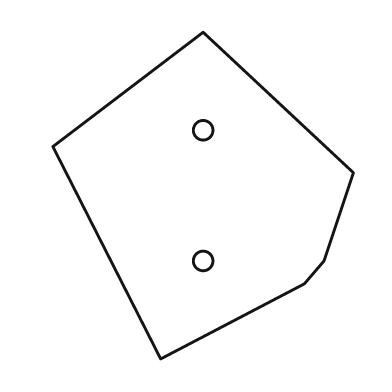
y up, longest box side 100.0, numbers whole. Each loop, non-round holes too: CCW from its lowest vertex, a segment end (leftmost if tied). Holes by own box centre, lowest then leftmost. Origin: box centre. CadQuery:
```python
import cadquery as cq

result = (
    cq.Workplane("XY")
    .moveTo(-13.0, -50.0)
    .lineTo(31.0, -27.0)
    .lineTo(37.0, -20.0)
    .lineTo(46.0, 7.0)
    .lineTo(0.0, 50.0)
    .lineTo(-46.0, 15.0)
    .close()
    .moveTo(0.0, -20.0)
    .circle(3.0)
    .moveTo(0.0, 20.0)
    .circle(3.0)
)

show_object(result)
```